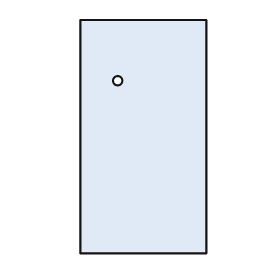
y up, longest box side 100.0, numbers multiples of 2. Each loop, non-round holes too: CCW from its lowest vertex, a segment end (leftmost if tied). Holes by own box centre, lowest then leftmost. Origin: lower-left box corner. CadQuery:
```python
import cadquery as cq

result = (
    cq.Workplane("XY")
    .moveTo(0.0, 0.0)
    .lineTo(54.0, 0.0)
    .lineTo(54.0, 100.0)
    .lineTo(0.0, 100.0)
    .close()
    .moveTo(16.0, 74.0)
    .circle(2.0)
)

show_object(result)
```